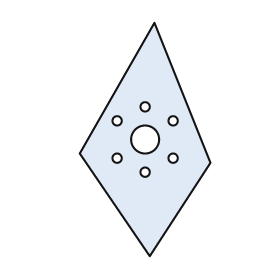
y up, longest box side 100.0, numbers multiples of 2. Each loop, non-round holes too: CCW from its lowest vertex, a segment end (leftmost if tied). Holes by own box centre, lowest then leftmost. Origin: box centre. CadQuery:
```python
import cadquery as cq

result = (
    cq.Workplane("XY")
    .moveTo(2.0, -50.0)
    .lineTo(28.0, -10.0)
    .lineTo(4.0, 50.0)
    .lineTo(-28.0, -6.0)
    .close()
    .moveTo(0.0, -14.0)
    .circle(2.0)
    .moveTo(-12.0, -8.0)
    .circle(2.0)
    .moveTo(12.0, -8.0)
    .circle(2.0)
    .moveTo(0.0, 0.0)
    .circle(6.0)
    .moveTo(-12.0, 8.0)
    .circle(2.0)
    .moveTo(12.0, 8.0)
    .circle(2.0)
    .moveTo(0.0, 14.0)
    .circle(2.0)
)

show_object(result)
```